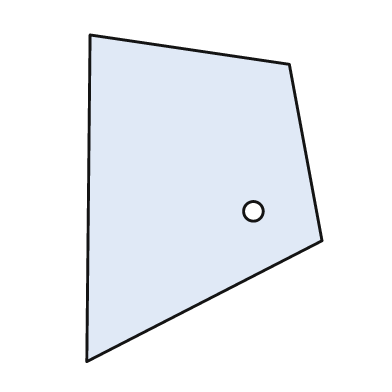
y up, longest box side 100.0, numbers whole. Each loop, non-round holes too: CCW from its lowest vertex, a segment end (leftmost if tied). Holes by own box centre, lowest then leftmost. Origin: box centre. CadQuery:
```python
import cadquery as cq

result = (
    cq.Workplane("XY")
    .moveTo(-36.0, -50.0)
    .lineTo(36.0, -13.0)
    .lineTo(26.0, 41.0)
    .lineTo(-35.0, 50.0)
    .close()
    .moveTo(15.0, -4.0)
    .circle(3.0)
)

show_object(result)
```